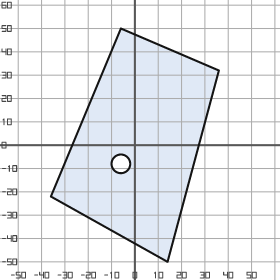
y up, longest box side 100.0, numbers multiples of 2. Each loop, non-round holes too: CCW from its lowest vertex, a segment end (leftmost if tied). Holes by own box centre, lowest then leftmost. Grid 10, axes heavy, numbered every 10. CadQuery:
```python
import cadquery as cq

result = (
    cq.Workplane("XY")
    .moveTo(14.0, -50.0)
    .lineTo(36.0, 32.0)
    .lineTo(-6.0, 50.0)
    .lineTo(-36.0, -22.0)
    .close()
    .moveTo(-6.0, -8.0)
    .circle(4.0)
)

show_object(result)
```